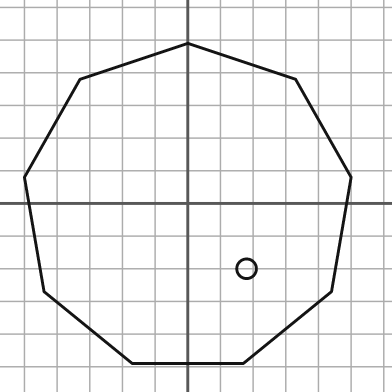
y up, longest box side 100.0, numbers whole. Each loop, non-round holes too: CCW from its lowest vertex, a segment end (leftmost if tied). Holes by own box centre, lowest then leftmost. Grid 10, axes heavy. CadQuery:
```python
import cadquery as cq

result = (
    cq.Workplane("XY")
    .moveTo(-17.0, -49.0)
    .lineTo(17.0, -49.0)
    .lineTo(44.0, -27.0)
    .lineTo(50.0, 8.0)
    .lineTo(33.0, 38.0)
    .lineTo(0.0, 49.0)
    .lineTo(-33.0, 38.0)
    .lineTo(-50.0, 8.0)
    .lineTo(-44.0, -27.0)
    .close()
    .moveTo(18.0, -20.0)
    .circle(3.0)
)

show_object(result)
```